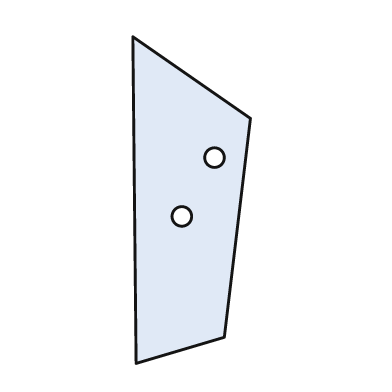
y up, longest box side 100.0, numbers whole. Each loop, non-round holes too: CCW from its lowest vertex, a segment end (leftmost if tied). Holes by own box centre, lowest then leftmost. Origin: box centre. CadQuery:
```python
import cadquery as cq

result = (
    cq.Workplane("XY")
    .moveTo(-17.0, -50.0)
    .lineTo(10.0, -42.0)
    .lineTo(18.0, 25.0)
    .lineTo(-18.0, 50.0)
    .close()
    .moveTo(-3.0, -5.0)
    .circle(3.0)
    .moveTo(7.0, 13.0)
    .circle(3.0)
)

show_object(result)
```